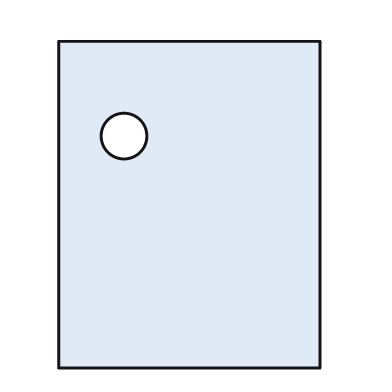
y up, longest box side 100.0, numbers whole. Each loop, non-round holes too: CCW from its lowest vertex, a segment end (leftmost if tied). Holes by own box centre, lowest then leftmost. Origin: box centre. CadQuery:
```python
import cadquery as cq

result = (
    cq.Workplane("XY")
    .moveTo(-40.0, -50.0)
    .lineTo(40.0, -50.0)
    .lineTo(40.0, 50.0)
    .lineTo(-40.0, 50.0)
    .close()
    .moveTo(-20.0, 21.0)
    .circle(7.0)
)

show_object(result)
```